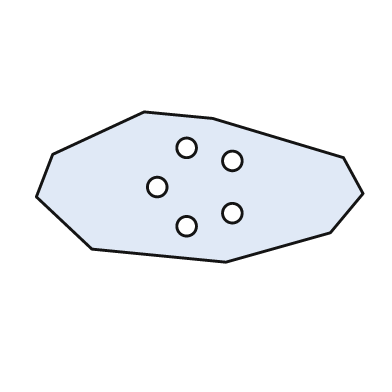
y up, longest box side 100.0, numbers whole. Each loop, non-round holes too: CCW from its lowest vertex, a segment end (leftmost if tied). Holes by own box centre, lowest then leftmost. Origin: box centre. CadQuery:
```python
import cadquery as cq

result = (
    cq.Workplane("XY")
    .moveTo(8.0, -23.0)
    .lineTo(40.0, -14.0)
    .lineTo(50.0, -2.0)
    .lineTo(44.0, 9.0)
    .lineTo(4.0, 21.0)
    .lineTo(-17.0, 23.0)
    .lineTo(-45.0, 10.0)
    .lineTo(-50.0, -3.0)
    .lineTo(-33.0, -19.0)
    .close()
    .moveTo(-4.0, -12.0)
    .circle(3.0)
    .moveTo(10.0, -8.0)
    .circle(3.0)
    .moveTo(-13.0, 0.0)
    .circle(3.0)
    .moveTo(10.0, 8.0)
    .circle(3.0)
    .moveTo(-4.0, 12.0)
    .circle(3.0)
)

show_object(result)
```